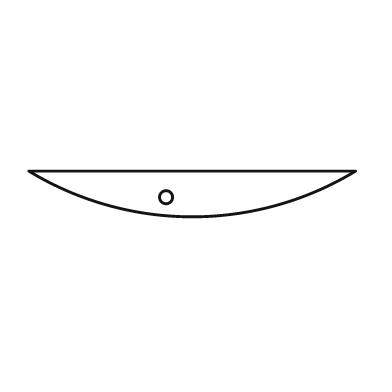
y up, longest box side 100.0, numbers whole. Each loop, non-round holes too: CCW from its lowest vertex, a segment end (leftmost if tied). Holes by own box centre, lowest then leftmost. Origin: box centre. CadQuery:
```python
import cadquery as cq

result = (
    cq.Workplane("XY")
    .moveTo(-50.0, 7.0)
    .threePointArc((0.0, -7.0), (50.0, 7.0))
    .close()
    .moveTo(-8.0, -1.0)
    .circle(2.0)
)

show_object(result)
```